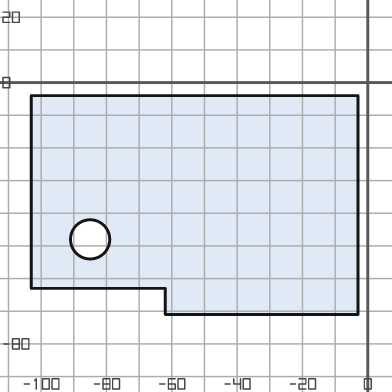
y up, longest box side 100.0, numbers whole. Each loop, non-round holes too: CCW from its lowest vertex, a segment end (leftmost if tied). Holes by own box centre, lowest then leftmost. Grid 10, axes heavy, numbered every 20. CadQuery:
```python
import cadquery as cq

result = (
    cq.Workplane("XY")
    .moveTo(-62.0, -71.0)
    .lineTo(-3.0, -71.0)
    .lineTo(-3.0, -4.0)
    .lineTo(-103.0, -4.0)
    .lineTo(-103.0, -63.0)
    .lineTo(-62.0, -63.0)
    .close()
    .moveTo(-85.0, -48.0)
    .circle(6.0)
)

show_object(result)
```